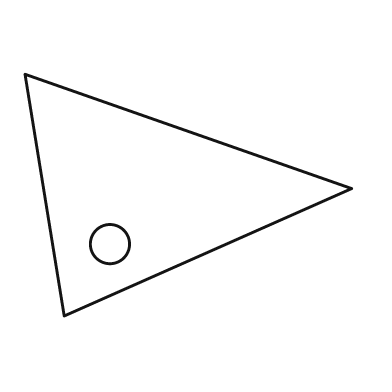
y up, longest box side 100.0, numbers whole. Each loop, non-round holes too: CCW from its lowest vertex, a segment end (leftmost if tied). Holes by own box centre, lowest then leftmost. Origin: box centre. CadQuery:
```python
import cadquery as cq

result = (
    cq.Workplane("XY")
    .moveTo(-38.0, -37.0)
    .lineTo(50.0, 2.0)
    .lineTo(-50.0, 37.0)
    .close()
    .moveTo(-24.0, -15.0)
    .circle(6.0)
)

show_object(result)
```